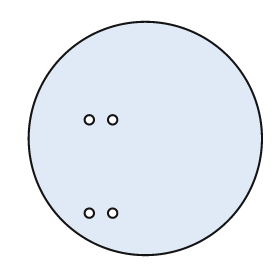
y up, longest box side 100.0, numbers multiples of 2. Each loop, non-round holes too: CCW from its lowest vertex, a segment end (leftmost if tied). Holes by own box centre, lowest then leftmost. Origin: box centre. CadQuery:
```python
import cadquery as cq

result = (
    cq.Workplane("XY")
    .moveTo(0.0, 0.0)
    .circle(50.0)
    .moveTo(-24.0, -32.0)
    .circle(2.0)
    .moveTo(-14.0, -32.0)
    .circle(2.0)
    .moveTo(-24.0, 8.0)
    .circle(2.0)
    .moveTo(-14.0, 8.0)
    .circle(2.0)
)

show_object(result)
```